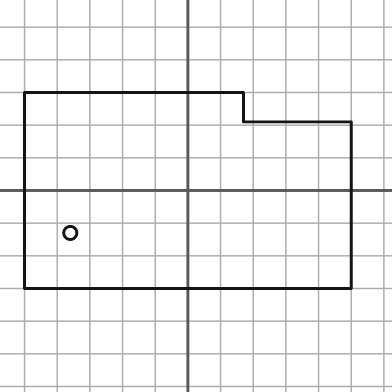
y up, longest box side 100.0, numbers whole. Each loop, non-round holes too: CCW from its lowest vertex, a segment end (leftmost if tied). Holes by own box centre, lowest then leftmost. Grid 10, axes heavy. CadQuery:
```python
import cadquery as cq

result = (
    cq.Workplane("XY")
    .moveTo(-50.0, -30.0)
    .lineTo(50.0, -30.0)
    .lineTo(50.0, 21.0)
    .lineTo(17.0, 21.0)
    .lineTo(17.0, 30.0)
    .lineTo(-50.0, 30.0)
    .close()
    .moveTo(-36.0, -13.0)
    .circle(2.0)
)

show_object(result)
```